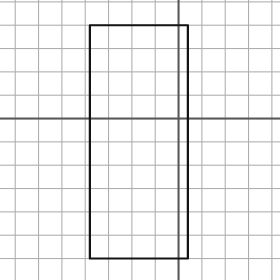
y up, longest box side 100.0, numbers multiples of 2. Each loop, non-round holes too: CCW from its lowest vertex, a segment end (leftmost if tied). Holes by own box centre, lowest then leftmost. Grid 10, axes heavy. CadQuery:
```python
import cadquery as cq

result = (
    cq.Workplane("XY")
    .moveTo(-38.0, -60.0)
    .lineTo(4.0, -60.0)
    .lineTo(4.0, 40.0)
    .lineTo(-38.0, 40.0)
    .close()
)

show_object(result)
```